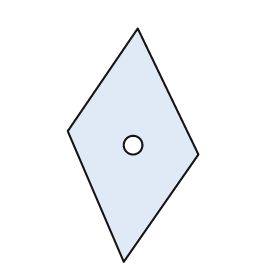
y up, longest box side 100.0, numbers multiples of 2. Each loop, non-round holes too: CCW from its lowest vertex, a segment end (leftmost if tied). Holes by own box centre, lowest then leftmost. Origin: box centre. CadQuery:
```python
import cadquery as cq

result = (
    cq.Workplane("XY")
    .moveTo(-4.0, -50.0)
    .lineTo(28.0, -4.0)
    .lineTo(2.0, 50.0)
    .lineTo(-28.0, 6.0)
    .close()
    .moveTo(0.0, 0.0)
    .circle(4.0)
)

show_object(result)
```